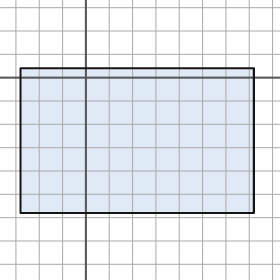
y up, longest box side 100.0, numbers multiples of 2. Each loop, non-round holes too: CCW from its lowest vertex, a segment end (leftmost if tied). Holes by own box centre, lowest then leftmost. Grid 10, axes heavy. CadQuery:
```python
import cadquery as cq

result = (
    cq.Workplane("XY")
    .moveTo(-28.0, -58.0)
    .lineTo(72.0, -58.0)
    .lineTo(72.0, 4.0)
    .lineTo(-28.0, 4.0)
    .close()
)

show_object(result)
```